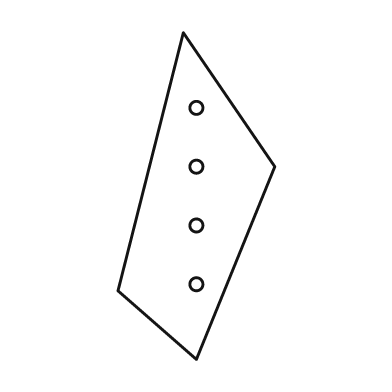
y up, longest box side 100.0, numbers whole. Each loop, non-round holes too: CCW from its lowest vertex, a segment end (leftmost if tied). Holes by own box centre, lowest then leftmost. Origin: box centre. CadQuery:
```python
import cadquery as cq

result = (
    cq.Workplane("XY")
    .moveTo(0.0, -50.0)
    .lineTo(24.0, 9.0)
    .lineTo(-4.0, 50.0)
    .lineTo(-24.0, -29.0)
    .close()
    .moveTo(0.0, -27.0)
    .circle(2.0)
    .moveTo(0.0, -9.0)
    .circle(2.0)
    .moveTo(0.0, 9.0)
    .circle(2.0)
    .moveTo(0.0, 27.0)
    .circle(2.0)
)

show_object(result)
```